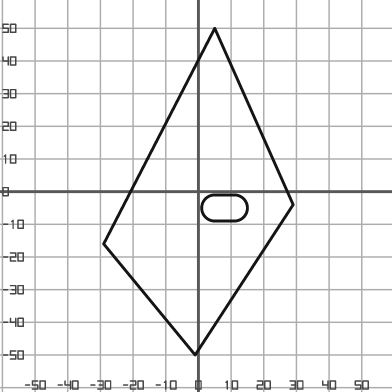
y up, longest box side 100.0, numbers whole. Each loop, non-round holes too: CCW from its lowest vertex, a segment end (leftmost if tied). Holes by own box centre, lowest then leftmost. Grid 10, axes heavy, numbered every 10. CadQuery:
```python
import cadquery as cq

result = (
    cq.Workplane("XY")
    .moveTo(-1.0, -50.0)
    .lineTo(29.0, -4.0)
    .lineTo(5.0, 50.0)
    .lineTo(-29.0, -16.0)
    .close()
    .moveTo(5.0, -9.0)
    .lineTo(11.0, -9.0)
    .threePointArc((15.0, -5.0), (11.0, -1.0))
    .lineTo(5.0, -1.0)
    .threePointArc((1.0, -5.0), (5.0, -9.0))
    .close()
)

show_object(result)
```